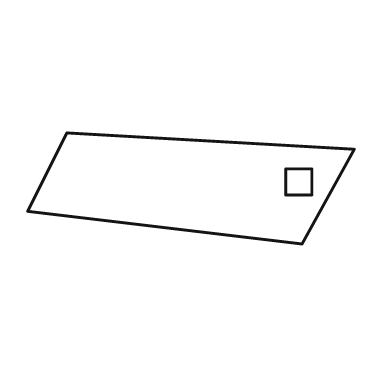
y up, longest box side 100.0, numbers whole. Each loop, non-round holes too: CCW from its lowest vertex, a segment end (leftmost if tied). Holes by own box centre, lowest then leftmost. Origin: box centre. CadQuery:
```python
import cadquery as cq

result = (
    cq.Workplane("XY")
    .moveTo(34.0, -17.0)
    .lineTo(50.0, 12.0)
    .lineTo(-38.0, 17.0)
    .lineTo(-50.0, -7.0)
    .close()
    .moveTo(29.0, -2.0)
    .lineTo(37.0, -2.0)
    .lineTo(37.0, 6.0)
    .lineTo(29.0, 6.0)
    .close()
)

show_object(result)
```